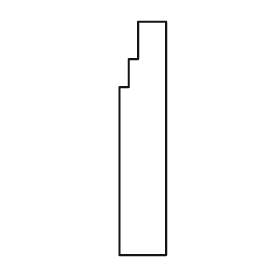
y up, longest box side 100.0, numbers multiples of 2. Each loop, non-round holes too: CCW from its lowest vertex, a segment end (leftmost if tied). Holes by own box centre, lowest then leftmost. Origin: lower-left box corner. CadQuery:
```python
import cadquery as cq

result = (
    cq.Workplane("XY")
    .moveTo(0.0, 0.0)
    .lineTo(20.0, 0.0)
    .lineTo(20.0, 100.0)
    .lineTo(8.0, 100.0)
    .lineTo(8.0, 84.0)
    .lineTo(4.0, 84.0)
    .lineTo(4.0, 72.0)
    .lineTo(0.0, 72.0)
    .close()
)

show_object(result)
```